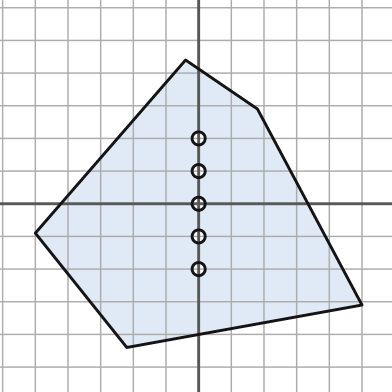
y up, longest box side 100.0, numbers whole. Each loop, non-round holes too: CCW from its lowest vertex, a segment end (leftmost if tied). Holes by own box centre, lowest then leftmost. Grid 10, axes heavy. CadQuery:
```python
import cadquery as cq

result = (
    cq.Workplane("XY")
    .moveTo(-22.0, -44.0)
    .lineTo(50.0, -31.0)
    .lineTo(18.0, 29.0)
    .lineTo(-4.0, 44.0)
    .lineTo(-50.0, -9.0)
    .close()
    .moveTo(0.0, -20.0)
    .circle(2.0)
    .moveTo(0.0, -10.0)
    .circle(2.0)
    .moveTo(0.0, 0.0)
    .circle(2.0)
    .moveTo(0.0, 10.0)
    .circle(2.0)
    .moveTo(0.0, 20.0)
    .circle(2.0)
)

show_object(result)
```